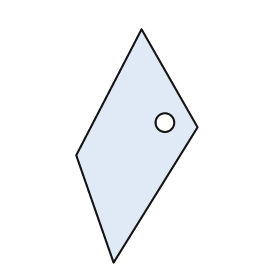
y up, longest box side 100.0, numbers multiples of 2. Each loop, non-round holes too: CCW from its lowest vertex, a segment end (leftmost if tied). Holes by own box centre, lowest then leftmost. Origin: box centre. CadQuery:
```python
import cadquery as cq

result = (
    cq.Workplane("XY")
    .moveTo(-10.0, -50.0)
    .lineTo(26.0, 8.0)
    .lineTo(2.0, 50.0)
    .lineTo(-26.0, -4.0)
    .close()
    .moveTo(12.0, 10.0)
    .circle(4.0)
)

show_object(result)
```